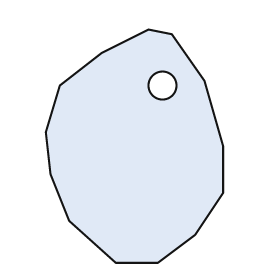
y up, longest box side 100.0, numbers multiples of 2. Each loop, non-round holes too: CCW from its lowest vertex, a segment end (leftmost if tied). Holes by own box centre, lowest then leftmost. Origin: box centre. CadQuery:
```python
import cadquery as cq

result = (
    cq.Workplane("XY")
    .moveTo(-8.0, -50.0)
    .lineTo(10.0, -50.0)
    .lineTo(26.0, -38.0)
    .lineTo(38.0, -20.0)
    .lineTo(38.0, 0.0)
    .lineTo(30.0, 28.0)
    .lineTo(16.0, 48.0)
    .lineTo(6.0, 50.0)
    .lineTo(-14.0, 40.0)
    .lineTo(-32.0, 26.0)
    .lineTo(-38.0, 6.0)
    .lineTo(-36.0, -12.0)
    .lineTo(-28.0, -32.0)
    .close()
    .moveTo(12.0, 26.0)
    .circle(6.0)
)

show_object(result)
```